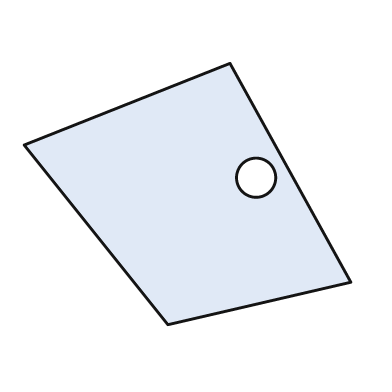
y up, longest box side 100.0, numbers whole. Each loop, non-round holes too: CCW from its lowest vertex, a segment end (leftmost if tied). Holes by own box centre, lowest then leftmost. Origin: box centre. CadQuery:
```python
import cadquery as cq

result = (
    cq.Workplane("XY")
    .moveTo(-6.0, -40.0)
    .lineTo(50.0, -27.0)
    .lineTo(13.0, 40.0)
    .lineTo(-50.0, 15.0)
    .close()
    .moveTo(21.0, 5.0)
    .circle(6.0)
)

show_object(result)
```